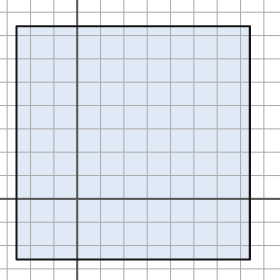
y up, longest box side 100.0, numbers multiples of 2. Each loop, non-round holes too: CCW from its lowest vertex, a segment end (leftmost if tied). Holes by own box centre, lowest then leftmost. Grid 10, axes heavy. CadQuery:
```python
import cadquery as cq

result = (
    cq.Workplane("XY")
    .moveTo(-26.0, -26.0)
    .lineTo(74.0, -26.0)
    .lineTo(74.0, 74.0)
    .lineTo(-26.0, 74.0)
    .close()
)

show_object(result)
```